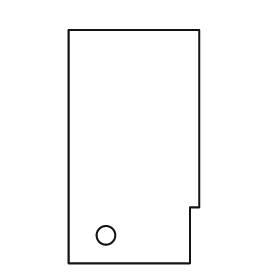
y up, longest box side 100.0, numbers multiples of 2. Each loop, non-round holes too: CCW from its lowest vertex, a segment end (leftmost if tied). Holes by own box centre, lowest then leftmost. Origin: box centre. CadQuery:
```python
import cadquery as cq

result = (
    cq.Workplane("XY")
    .moveTo(-28.0, -50.0)
    .lineTo(24.0, -50.0)
    .lineTo(24.0, -26.0)
    .lineTo(28.0, -26.0)
    .lineTo(28.0, 50.0)
    .lineTo(-28.0, 50.0)
    .close()
    .moveTo(-12.0, -38.0)
    .circle(4.0)
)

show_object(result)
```